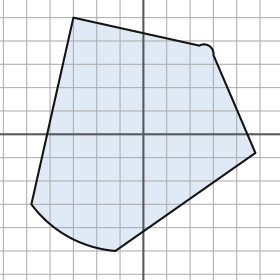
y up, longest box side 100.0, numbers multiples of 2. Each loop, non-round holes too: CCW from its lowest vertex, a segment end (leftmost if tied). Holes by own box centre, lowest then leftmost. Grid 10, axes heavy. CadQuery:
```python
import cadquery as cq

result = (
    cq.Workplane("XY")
    .moveTo(-12.0, -50.0)
    .lineTo(48.0, -8.0)
    .lineTo(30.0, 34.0)
    .threePointArc((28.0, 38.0), (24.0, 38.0))
    .lineTo(-30.0, 50.0)
    .lineTo(-48.0, -30.0)
    .threePointArc((-32.0, -44.0), (-12.0, -50.0))
    .close()
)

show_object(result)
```